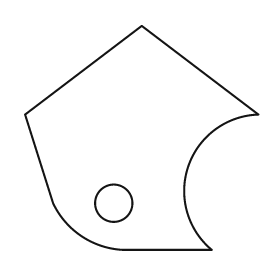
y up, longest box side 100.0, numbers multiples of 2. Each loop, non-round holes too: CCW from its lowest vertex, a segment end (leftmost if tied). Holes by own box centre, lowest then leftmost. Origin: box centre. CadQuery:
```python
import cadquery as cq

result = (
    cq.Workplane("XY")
    .moveTo(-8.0, -48.0)
    .lineTo(30.0, -48.0)
    .threePointArc((20.0, -12.0), (50.0, 10.0))
    .lineTo(0.0, 48.0)
    .lineTo(-50.0, 10.0)
    .lineTo(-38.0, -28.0)
    .threePointArc((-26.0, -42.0), (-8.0, -48.0))
    .close()
    .moveTo(-12.0, -28.0)
    .circle(8.0)
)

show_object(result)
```